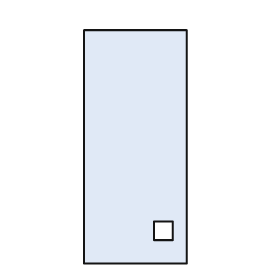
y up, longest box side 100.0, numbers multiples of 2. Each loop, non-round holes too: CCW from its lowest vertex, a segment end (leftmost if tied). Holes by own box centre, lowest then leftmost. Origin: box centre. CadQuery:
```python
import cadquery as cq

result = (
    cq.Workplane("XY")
    .moveTo(-22.0, -50.0)
    .lineTo(22.0, -50.0)
    .lineTo(22.0, 50.0)
    .lineTo(-22.0, 50.0)
    .close()
    .moveTo(8.0, -40.0)
    .lineTo(16.0, -40.0)
    .lineTo(16.0, -32.0)
    .lineTo(8.0, -32.0)
    .close()
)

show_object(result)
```